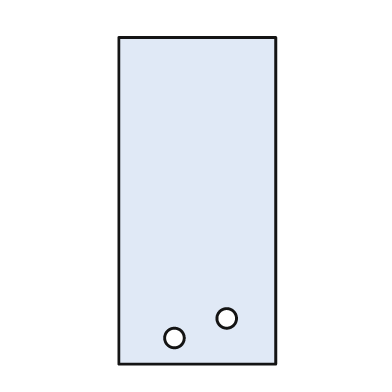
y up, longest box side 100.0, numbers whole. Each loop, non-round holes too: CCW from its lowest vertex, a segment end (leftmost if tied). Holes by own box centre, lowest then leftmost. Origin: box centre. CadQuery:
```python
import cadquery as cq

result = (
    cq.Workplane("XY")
    .moveTo(-24.0, -50.0)
    .lineTo(24.0, -50.0)
    .lineTo(24.0, 50.0)
    .lineTo(-24.0, 50.0)
    .close()
    .moveTo(-7.0, -42.0)
    .circle(3.0)
    .moveTo(9.0, -36.0)
    .circle(3.0)
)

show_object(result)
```